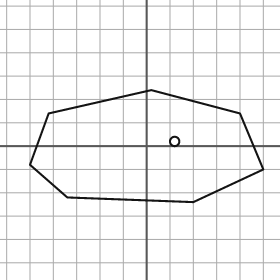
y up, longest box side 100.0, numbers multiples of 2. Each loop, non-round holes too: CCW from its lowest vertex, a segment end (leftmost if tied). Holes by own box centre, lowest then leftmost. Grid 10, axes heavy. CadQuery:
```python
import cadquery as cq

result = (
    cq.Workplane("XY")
    .moveTo(20.0, -24.0)
    .lineTo(50.0, -10.0)
    .lineTo(40.0, 14.0)
    .lineTo(2.0, 24.0)
    .lineTo(-42.0, 14.0)
    .lineTo(-50.0, -8.0)
    .lineTo(-34.0, -22.0)
    .close()
    .moveTo(12.0, 2.0)
    .circle(2.0)
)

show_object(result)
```